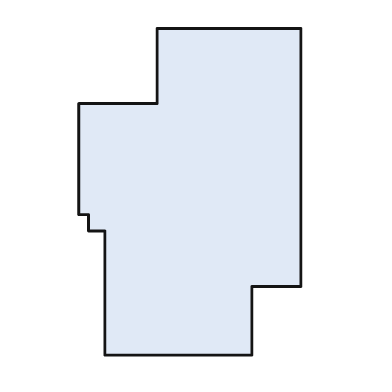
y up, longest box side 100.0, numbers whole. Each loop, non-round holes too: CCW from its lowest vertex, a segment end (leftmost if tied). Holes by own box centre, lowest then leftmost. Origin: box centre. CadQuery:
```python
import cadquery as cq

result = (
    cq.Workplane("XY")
    .moveTo(-26.0, -50.0)
    .lineTo(19.0, -50.0)
    .lineTo(19.0, -29.0)
    .lineTo(34.0, -29.0)
    .lineTo(34.0, 50.0)
    .lineTo(-10.0, 50.0)
    .lineTo(-10.0, 27.0)
    .lineTo(-34.0, 27.0)
    .lineTo(-34.0, -7.0)
    .lineTo(-31.0, -7.0)
    .lineTo(-31.0, -12.0)
    .lineTo(-26.0, -12.0)
    .close()
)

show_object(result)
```